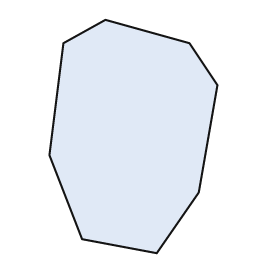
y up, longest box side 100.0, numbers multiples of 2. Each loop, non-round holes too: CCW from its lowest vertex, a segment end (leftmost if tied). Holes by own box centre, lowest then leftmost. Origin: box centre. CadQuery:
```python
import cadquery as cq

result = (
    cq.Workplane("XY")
    .moveTo(10.0, -50.0)
    .lineTo(28.0, -24.0)
    .lineTo(36.0, 22.0)
    .lineTo(24.0, 40.0)
    .lineTo(-12.0, 50.0)
    .lineTo(-30.0, 40.0)
    .lineTo(-36.0, -8.0)
    .lineTo(-22.0, -44.0)
    .close()
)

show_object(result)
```